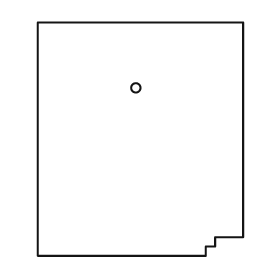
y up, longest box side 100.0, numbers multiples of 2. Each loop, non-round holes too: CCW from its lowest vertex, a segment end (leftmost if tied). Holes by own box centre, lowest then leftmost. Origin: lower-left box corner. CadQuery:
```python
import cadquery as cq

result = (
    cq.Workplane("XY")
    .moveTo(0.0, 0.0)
    .lineTo(72.0, 0.0)
    .lineTo(72.0, 4.0)
    .lineTo(76.0, 4.0)
    .lineTo(76.0, 8.0)
    .lineTo(88.0, 8.0)
    .lineTo(88.0, 100.0)
    .lineTo(0.0, 100.0)
    .close()
    .moveTo(42.0, 72.0)
    .circle(2.0)
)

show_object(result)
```